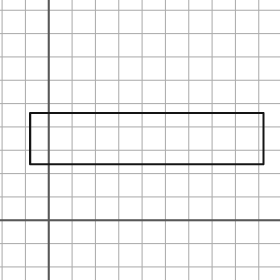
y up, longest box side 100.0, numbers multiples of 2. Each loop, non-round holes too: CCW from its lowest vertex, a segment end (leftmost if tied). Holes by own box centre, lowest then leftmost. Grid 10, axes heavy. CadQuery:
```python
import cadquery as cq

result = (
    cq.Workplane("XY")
    .moveTo(-8.0, 24.0)
    .lineTo(92.0, 24.0)
    .lineTo(92.0, 46.0)
    .lineTo(-8.0, 46.0)
    .close()
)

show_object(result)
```